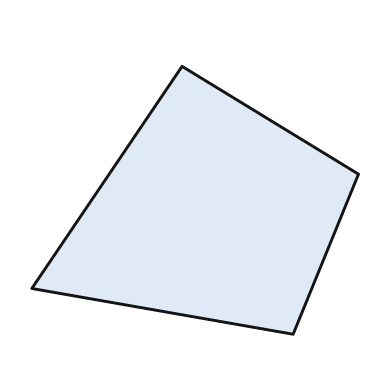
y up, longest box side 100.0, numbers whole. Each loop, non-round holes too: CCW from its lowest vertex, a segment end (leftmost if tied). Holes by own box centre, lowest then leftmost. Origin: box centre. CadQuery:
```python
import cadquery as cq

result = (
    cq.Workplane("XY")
    .moveTo(30.0, -41.0)
    .lineTo(50.0, 8.0)
    .lineTo(-4.0, 41.0)
    .lineTo(-50.0, -27.0)
    .close()
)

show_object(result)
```